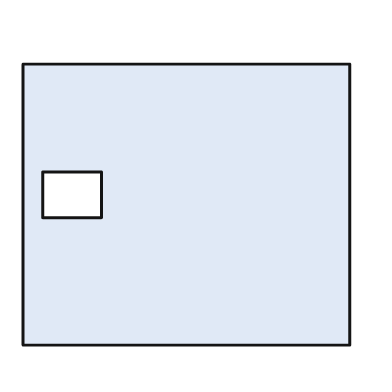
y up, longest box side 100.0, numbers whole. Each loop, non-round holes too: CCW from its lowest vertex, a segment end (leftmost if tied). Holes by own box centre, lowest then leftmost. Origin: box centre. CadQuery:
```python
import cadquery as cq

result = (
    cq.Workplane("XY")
    .moveTo(-50.0, -43.0)
    .lineTo(50.0, -43.0)
    .lineTo(50.0, 43.0)
    .lineTo(-50.0, 43.0)
    .close()
    .moveTo(-44.0, -4.0)
    .lineTo(-26.0, -4.0)
    .lineTo(-26.0, 10.0)
    .lineTo(-44.0, 10.0)
    .close()
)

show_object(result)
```